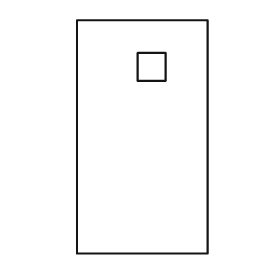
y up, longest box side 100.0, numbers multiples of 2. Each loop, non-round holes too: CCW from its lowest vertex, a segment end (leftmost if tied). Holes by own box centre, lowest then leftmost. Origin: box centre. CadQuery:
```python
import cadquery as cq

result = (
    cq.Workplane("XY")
    .moveTo(-28.0, -50.0)
    .lineTo(28.0, -50.0)
    .lineTo(28.0, 50.0)
    .lineTo(-28.0, 50.0)
    .close()
    .moveTo(-2.0, 24.0)
    .lineTo(10.0, 24.0)
    .lineTo(10.0, 36.0)
    .lineTo(-2.0, 36.0)
    .close()
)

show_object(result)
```